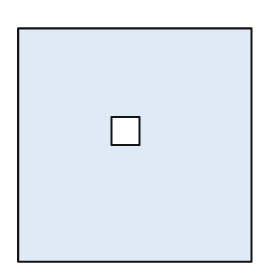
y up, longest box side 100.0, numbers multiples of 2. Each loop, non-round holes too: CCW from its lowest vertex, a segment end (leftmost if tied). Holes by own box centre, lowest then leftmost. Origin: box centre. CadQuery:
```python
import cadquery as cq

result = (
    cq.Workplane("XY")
    .moveTo(-50.0, -50.0)
    .lineTo(50.0, -50.0)
    .lineTo(50.0, 50.0)
    .lineTo(-50.0, 50.0)
    .close()
    .moveTo(-10.0, 0.0)
    .lineTo(2.0, 0.0)
    .lineTo(2.0, 12.0)
    .lineTo(-10.0, 12.0)
    .close()
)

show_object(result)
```